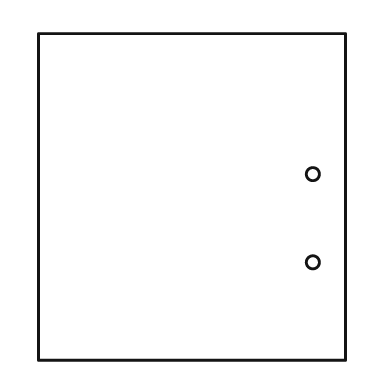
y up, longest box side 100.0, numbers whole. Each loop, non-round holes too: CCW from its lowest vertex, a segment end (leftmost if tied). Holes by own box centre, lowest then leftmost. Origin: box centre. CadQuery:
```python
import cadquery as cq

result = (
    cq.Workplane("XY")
    .moveTo(-47.0, -50.0)
    .lineTo(47.0, -50.0)
    .lineTo(47.0, 50.0)
    .lineTo(-47.0, 50.0)
    .close()
    .moveTo(37.0, -20.0)
    .circle(2.0)
    .moveTo(37.0, 7.0)
    .circle(2.0)
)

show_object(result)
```